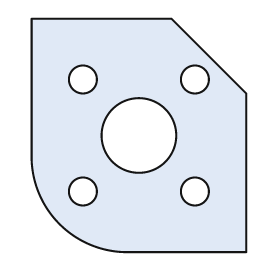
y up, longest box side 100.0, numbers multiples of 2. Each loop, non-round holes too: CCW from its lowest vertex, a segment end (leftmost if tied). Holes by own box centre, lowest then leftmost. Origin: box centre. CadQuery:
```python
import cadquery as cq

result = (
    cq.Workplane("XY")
    .moveTo(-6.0, -50.0)
    .lineTo(46.0, -50.0)
    .lineTo(46.0, 18.0)
    .lineTo(14.0, 50.0)
    .lineTo(-46.0, 50.0)
    .lineTo(-46.0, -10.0)
    .threePointArc((-34.0, -38.0), (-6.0, -50.0))
    .close()
    .moveTo(-24.0, -24.0)
    .circle(6.0)
    .moveTo(24.0, -24.0)
    .circle(6.0)
    .moveTo(0.0, 0.0)
    .circle(16.0)
    .moveTo(-24.0, 24.0)
    .circle(6.0)
    .moveTo(24.0, 24.0)
    .circle(6.0)
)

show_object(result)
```